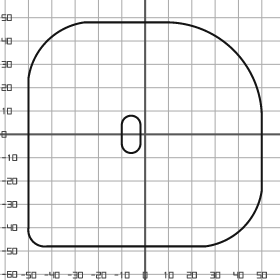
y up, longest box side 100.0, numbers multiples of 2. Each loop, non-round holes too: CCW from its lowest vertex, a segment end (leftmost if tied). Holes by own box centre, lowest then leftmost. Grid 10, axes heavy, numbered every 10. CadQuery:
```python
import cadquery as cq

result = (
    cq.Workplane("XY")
    .moveTo(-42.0, -48.0)
    .lineTo(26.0, -48.0)
    .threePointArc((42.0, -40.0), (50.0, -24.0))
    .lineTo(50.0, 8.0)
    .threePointArc((38.0, 36.0), (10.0, 48.0))
    .lineTo(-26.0, 48.0)
    .threePointArc((-42.0, 40.0), (-50.0, 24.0))
    .lineTo(-50.0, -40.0)
    .threePointArc((-48.0, -46.0), (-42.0, -48.0))
    .close()
    .moveTo(-10.0, -4.0)
    .threePointArc((-6.0, -8.0), (-2.0, -4.0))
    .lineTo(-2.0, 4.0)
    .threePointArc((-6.0, 8.0), (-10.0, 4.0))
    .close()
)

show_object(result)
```